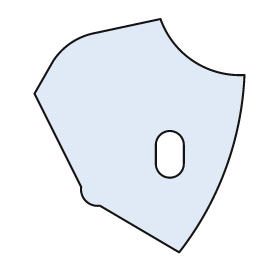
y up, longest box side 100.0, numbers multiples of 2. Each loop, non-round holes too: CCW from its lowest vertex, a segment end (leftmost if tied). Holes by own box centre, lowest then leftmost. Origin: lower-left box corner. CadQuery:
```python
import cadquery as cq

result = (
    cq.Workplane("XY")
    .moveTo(62.0, 0.0)
    .threePointArc((82.0, 36.0), (90.0, 76.0))
    .threePointArc((68.0, 82.0), (54.0, 100.0))
    .lineTo(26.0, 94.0)
    .threePointArc((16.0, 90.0), (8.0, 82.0))
    .lineTo(0.0, 68.0)
    .lineTo(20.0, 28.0)
    .threePointArc((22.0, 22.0), (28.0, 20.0))
    .close()
    .moveTo(52.0, 38.0)
    .threePointArc((58.0, 32.0), (64.0, 38.0))
    .lineTo(64.0, 46.0)
    .threePointArc((58.0, 52.0), (52.0, 46.0))
    .close()
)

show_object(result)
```